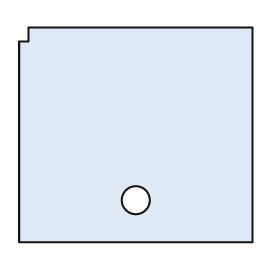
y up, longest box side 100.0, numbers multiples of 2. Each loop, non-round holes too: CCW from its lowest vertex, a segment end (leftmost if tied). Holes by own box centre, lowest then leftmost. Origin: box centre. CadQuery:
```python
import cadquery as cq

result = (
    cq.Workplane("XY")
    .moveTo(-50.0, -46.0)
    .lineTo(50.0, -46.0)
    .lineTo(50.0, 46.0)
    .lineTo(-46.0, 46.0)
    .lineTo(-46.0, 40.0)
    .lineTo(-50.0, 40.0)
    .close()
    .moveTo(0.0, -28.0)
    .circle(6.0)
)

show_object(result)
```